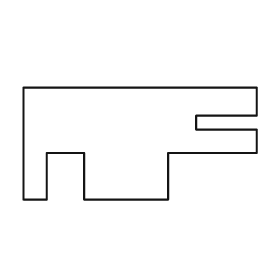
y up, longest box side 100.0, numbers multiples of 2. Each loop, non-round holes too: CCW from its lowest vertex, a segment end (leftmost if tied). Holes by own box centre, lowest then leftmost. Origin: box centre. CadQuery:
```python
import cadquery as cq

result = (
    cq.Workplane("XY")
    .moveTo(-50.0, -24.0)
    .lineTo(-40.0, -24.0)
    .lineTo(-40.0, -4.0)
    .lineTo(-24.0, -4.0)
    .lineTo(-24.0, -24.0)
    .lineTo(12.0, -24.0)
    .lineTo(12.0, -4.0)
    .lineTo(50.0, -4.0)
    .lineTo(50.0, 6.0)
    .lineTo(24.0, 6.0)
    .lineTo(24.0, 12.0)
    .lineTo(50.0, 12.0)
    .lineTo(50.0, 24.0)
    .lineTo(-50.0, 24.0)
    .close()
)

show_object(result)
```